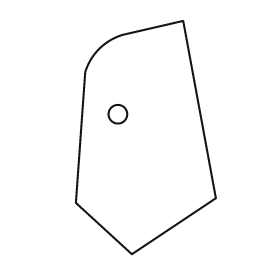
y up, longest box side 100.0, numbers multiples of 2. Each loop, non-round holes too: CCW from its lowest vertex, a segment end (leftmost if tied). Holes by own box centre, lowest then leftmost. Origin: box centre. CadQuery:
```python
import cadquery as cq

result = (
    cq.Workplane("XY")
    .moveTo(-6.0, -50.0)
    .lineTo(30.0, -26.0)
    .lineTo(16.0, 50.0)
    .lineTo(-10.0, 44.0)
    .threePointArc((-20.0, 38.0), (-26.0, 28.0))
    .lineTo(-30.0, -28.0)
    .close()
    .moveTo(-12.0, 10.0)
    .circle(4.0)
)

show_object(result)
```